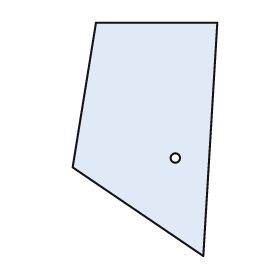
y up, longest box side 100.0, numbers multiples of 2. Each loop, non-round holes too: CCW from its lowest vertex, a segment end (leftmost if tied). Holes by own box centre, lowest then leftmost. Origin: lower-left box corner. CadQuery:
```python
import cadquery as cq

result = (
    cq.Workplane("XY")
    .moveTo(56.0, 0.0)
    .lineTo(62.0, 100.0)
    .lineTo(10.0, 100.0)
    .lineTo(0.0, 38.0)
    .close()
    .moveTo(44.0, 42.0)
    .circle(2.0)
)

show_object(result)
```